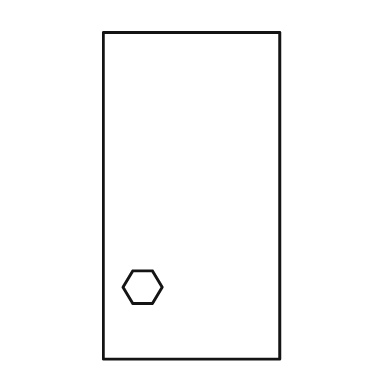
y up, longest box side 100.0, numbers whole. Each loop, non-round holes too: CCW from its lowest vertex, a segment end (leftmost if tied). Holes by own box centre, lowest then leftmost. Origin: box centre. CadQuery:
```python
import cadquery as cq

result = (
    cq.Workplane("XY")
    .moveTo(-27.0, -50.0)
    .lineTo(27.0, -50.0)
    .lineTo(27.0, 50.0)
    .lineTo(-27.0, 50.0)
    .close()
    .moveTo(-18.0, -33.0)
    .lineTo(-12.0, -33.0)
    .lineTo(-9.0, -28.0)
    .lineTo(-12.0, -23.0)
    .lineTo(-18.0, -23.0)
    .lineTo(-21.0, -28.0)
    .close()
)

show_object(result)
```